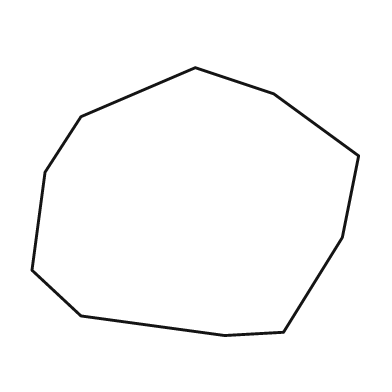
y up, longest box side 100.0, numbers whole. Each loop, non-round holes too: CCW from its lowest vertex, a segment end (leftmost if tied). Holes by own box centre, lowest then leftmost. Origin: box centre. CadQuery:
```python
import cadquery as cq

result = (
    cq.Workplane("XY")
    .moveTo(9.0, -41.0)
    .lineTo(27.0, -40.0)
    .lineTo(45.0, -11.0)
    .lineTo(50.0, 14.0)
    .lineTo(24.0, 33.0)
    .lineTo(0.0, 41.0)
    .lineTo(-35.0, 26.0)
    .lineTo(-46.0, 9.0)
    .lineTo(-50.0, -21.0)
    .lineTo(-35.0, -35.0)
    .close()
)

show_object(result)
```